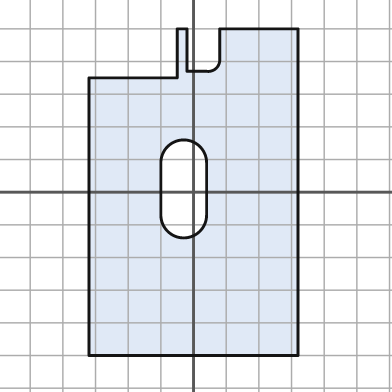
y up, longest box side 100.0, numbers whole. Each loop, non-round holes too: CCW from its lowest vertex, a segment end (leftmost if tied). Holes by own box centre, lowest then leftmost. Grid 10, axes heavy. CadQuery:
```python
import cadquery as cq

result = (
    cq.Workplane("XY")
    .moveTo(-32.0, -50.0)
    .lineTo(32.0, -50.0)
    .lineTo(32.0, 50.0)
    .lineTo(8.0, 50.0)
    .lineTo(8.0, 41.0)
    .threePointArc((7.0, 38.0), (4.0, 37.0))
    .lineTo(-2.0, 37.0)
    .lineTo(-2.0, 50.0)
    .lineTo(-5.0, 50.0)
    .lineTo(-5.0, 35.0)
    .lineTo(-32.0, 35.0)
    .close()
    .moveTo(-10.0, -7.0)
    .threePointArc((-3.0, -14.0), (4.0, -7.0))
    .lineTo(4.0, 9.0)
    .threePointArc((-3.0, 16.0), (-10.0, 9.0))
    .close()
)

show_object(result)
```